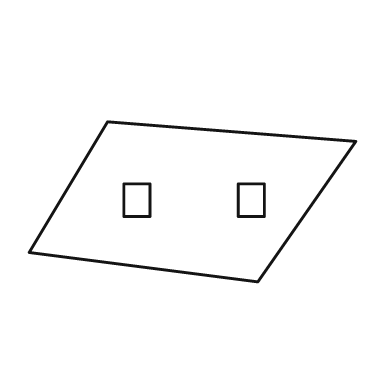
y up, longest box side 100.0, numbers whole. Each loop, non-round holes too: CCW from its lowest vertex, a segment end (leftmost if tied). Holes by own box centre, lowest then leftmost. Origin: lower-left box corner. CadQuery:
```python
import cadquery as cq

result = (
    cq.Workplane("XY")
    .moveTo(70.0, 0.0)
    .lineTo(100.0, 43.0)
    .lineTo(24.0, 49.0)
    .lineTo(0.0, 9.0)
    .close()
    .moveTo(29.0, 20.0)
    .lineTo(37.0, 20.0)
    .lineTo(37.0, 30.0)
    .lineTo(29.0, 30.0)
    .close()
    .moveTo(64.0, 20.0)
    .lineTo(72.0, 20.0)
    .lineTo(72.0, 30.0)
    .lineTo(64.0, 30.0)
    .close()
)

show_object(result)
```